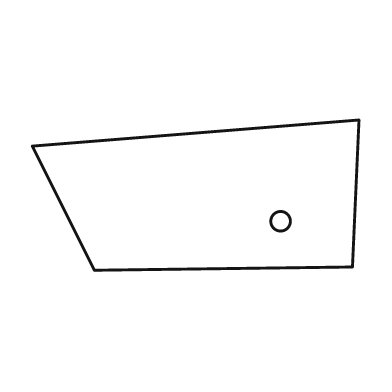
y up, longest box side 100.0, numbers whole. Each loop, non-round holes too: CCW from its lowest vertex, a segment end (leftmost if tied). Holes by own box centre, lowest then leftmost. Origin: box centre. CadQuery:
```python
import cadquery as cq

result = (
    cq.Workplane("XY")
    .moveTo(-31.0, -23.0)
    .lineTo(48.0, -22.0)
    .lineTo(50.0, 23.0)
    .lineTo(-50.0, 15.0)
    .close()
    .moveTo(26.0, -8.0)
    .circle(3.0)
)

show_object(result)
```